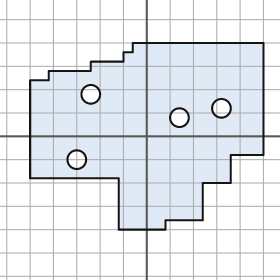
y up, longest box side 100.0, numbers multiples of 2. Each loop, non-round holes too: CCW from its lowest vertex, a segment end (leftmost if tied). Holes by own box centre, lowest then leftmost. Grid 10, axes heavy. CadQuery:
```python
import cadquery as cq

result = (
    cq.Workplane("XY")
    .moveTo(-12.0, -40.0)
    .lineTo(8.0, -40.0)
    .lineTo(8.0, -36.0)
    .lineTo(24.0, -36.0)
    .lineTo(24.0, -20.0)
    .lineTo(36.0, -20.0)
    .lineTo(36.0, -8.0)
    .lineTo(50.0, -8.0)
    .lineTo(50.0, 40.0)
    .lineTo(-6.0, 40.0)
    .lineTo(-6.0, 36.0)
    .lineTo(-10.0, 36.0)
    .lineTo(-10.0, 32.0)
    .lineTo(-24.0, 32.0)
    .lineTo(-24.0, 28.0)
    .lineTo(-42.0, 28.0)
    .lineTo(-42.0, 24.0)
    .lineTo(-50.0, 24.0)
    .lineTo(-50.0, -18.0)
    .lineTo(-12.0, -18.0)
    .close()
    .moveTo(-30.0, -10.0)
    .circle(4.0)
    .moveTo(14.0, 8.0)
    .circle(4.0)
    .moveTo(32.0, 12.0)
    .circle(4.0)
    .moveTo(-24.0, 18.0)
    .circle(4.0)
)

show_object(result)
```